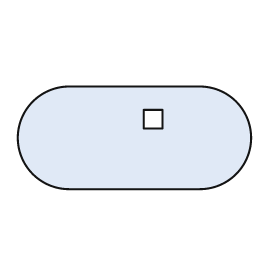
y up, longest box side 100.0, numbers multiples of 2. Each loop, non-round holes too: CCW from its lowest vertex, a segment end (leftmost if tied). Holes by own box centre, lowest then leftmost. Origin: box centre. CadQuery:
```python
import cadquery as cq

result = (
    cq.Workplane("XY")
    .moveTo(-28.0, -22.0)
    .lineTo(28.0, -22.0)
    .threePointArc((50.0, 0.0), (28.0, 22.0))
    .lineTo(-28.0, 22.0)
    .threePointArc((-50.0, 0.0), (-28.0, -22.0))
    .close()
    .moveTo(4.0, 4.0)
    .lineTo(12.0, 4.0)
    .lineTo(12.0, 12.0)
    .lineTo(4.0, 12.0)
    .close()
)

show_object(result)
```